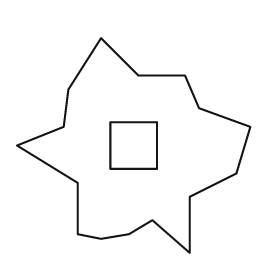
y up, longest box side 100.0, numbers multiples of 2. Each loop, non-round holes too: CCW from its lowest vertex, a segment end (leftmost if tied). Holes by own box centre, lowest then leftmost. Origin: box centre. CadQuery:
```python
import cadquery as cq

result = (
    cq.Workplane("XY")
    .moveTo(24.0, -46.0)
    .lineTo(24.0, -22.0)
    .lineTo(44.0, -12.0)
    .lineTo(50.0, 8.0)
    .lineTo(28.0, 16.0)
    .lineTo(22.0, 30.0)
    .lineTo(2.0, 30.0)
    .lineTo(-14.0, 46.0)
    .lineTo(-28.0, 24.0)
    .lineTo(-30.0, 8.0)
    .lineTo(-50.0, 0.0)
    .lineTo(-24.0, -16.0)
    .lineTo(-24.0, -38.0)
    .lineTo(-14.0, -40.0)
    .lineTo(-2.0, -38.0)
    .lineTo(8.0, -32.0)
    .close()
    .moveTo(-10.0, -10.0)
    .lineTo(10.0, -10.0)
    .lineTo(10.0, 10.0)
    .lineTo(-10.0, 10.0)
    .close()
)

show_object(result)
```